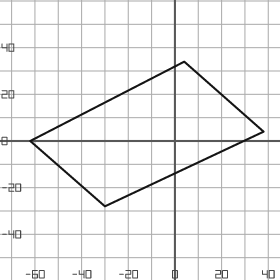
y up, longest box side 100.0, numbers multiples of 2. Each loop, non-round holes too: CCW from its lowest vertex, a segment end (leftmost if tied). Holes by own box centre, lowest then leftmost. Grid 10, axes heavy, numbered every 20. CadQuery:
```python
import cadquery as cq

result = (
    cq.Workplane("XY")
    .moveTo(-30.0, -28.0)
    .lineTo(38.0, 4.0)
    .lineTo(4.0, 34.0)
    .lineTo(-62.0, 0.0)
    .close()
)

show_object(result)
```